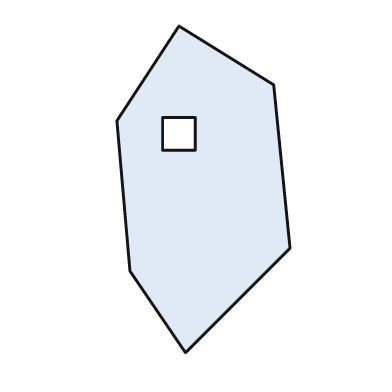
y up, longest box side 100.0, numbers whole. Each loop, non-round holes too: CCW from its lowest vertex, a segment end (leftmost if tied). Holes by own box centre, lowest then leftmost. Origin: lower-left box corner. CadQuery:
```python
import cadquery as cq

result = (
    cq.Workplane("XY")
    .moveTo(21.0, 0.0)
    .lineTo(53.0, 32.0)
    .lineTo(48.0, 82.0)
    .lineTo(19.0, 100.0)
    .lineTo(0.0, 71.0)
    .lineTo(4.0, 25.0)
    .close()
    .moveTo(14.0, 62.0)
    .lineTo(24.0, 62.0)
    .lineTo(24.0, 72.0)
    .lineTo(14.0, 72.0)
    .close()
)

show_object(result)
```